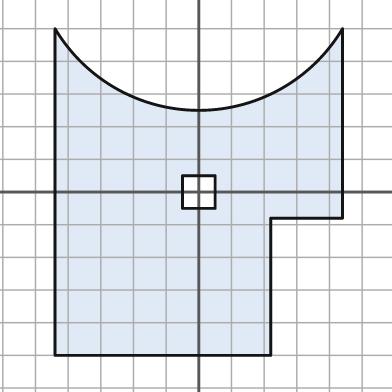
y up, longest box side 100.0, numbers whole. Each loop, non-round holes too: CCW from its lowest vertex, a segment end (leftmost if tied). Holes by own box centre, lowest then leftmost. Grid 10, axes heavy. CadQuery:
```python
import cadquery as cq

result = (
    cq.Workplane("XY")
    .moveTo(-44.0, -50.0)
    .lineTo(22.0, -50.0)
    .lineTo(22.0, -8.0)
    .lineTo(44.0, -8.0)
    .lineTo(44.0, 50.0)
    .threePointArc((0.0, 25.0), (-44.0, 50.0))
    .close()
    .moveTo(-5.0, -5.0)
    .lineTo(5.0, -5.0)
    .lineTo(5.0, 5.0)
    .lineTo(-5.0, 5.0)
    .close()
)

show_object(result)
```